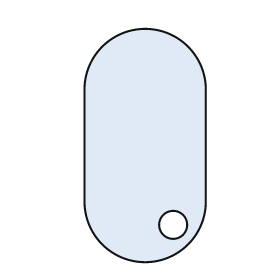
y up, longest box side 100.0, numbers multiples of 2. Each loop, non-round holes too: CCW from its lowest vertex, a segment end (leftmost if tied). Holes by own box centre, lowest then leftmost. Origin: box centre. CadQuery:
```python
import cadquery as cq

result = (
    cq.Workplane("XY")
    .moveTo(-26.0, -24.0)
    .threePointArc((0.0, -50.0), (26.0, -24.0))
    .lineTo(26.0, 24.0)
    .threePointArc((0.0, 50.0), (-26.0, 24.0))
    .close()
    .moveTo(12.0, -34.0)
    .circle(6.0)
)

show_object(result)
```